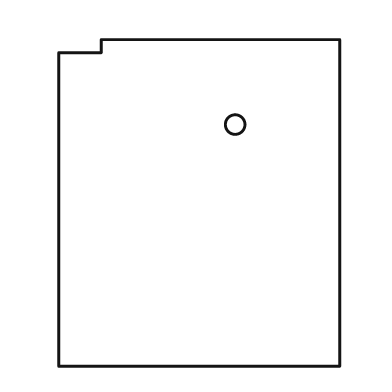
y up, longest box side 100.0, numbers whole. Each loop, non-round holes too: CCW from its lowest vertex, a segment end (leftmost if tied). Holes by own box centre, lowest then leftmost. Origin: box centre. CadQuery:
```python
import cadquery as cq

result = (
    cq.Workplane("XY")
    .moveTo(-43.0, -50.0)
    .lineTo(43.0, -50.0)
    .lineTo(43.0, 50.0)
    .lineTo(-30.0, 50.0)
    .lineTo(-30.0, 46.0)
    .lineTo(-43.0, 46.0)
    .close()
    .moveTo(11.0, 24.0)
    .circle(3.0)
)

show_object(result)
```